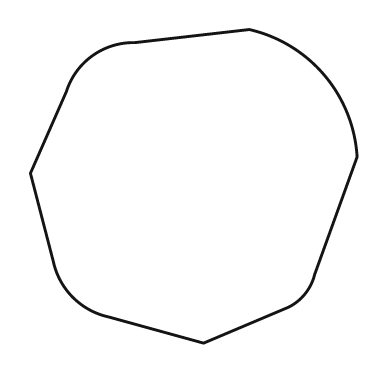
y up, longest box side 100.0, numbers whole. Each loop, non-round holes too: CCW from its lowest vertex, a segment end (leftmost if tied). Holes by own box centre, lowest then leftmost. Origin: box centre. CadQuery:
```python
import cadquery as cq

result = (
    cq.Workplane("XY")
    .moveTo(3.0, -48.0)
    .lineTo(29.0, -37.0)
    .threePointArc((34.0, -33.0), (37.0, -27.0))
    .lineTo(50.0, 9.0)
    .threePointArc((40.0, 34.0), (17.0, 48.0))
    .lineTo(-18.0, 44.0)
    .threePointArc((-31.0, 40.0), (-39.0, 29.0))
    .lineTo(-50.0, 4.0)
    .lineTo(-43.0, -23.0)
    .threePointArc((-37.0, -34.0), (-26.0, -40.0))
    .close()
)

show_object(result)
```